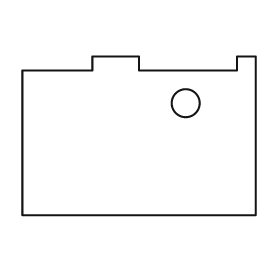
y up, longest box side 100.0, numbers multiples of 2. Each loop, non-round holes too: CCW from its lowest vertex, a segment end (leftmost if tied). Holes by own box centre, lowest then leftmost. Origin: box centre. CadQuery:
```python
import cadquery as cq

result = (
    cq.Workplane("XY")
    .moveTo(-50.0, -34.0)
    .lineTo(50.0, -34.0)
    .lineTo(50.0, 34.0)
    .lineTo(42.0, 34.0)
    .lineTo(42.0, 28.0)
    .lineTo(0.0, 28.0)
    .lineTo(0.0, 34.0)
    .lineTo(-20.0, 34.0)
    .lineTo(-20.0, 28.0)
    .lineTo(-50.0, 28.0)
    .close()
    .moveTo(20.0, 14.0)
    .circle(6.0)
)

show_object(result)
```